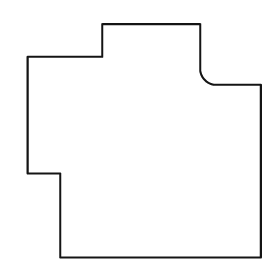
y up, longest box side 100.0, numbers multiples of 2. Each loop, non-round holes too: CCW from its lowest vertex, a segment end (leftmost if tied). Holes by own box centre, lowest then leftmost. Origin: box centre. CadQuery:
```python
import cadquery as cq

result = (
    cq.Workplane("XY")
    .moveTo(-36.0, -50.0)
    .lineTo(50.0, -50.0)
    .lineTo(50.0, 24.0)
    .lineTo(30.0, 24.0)
    .threePointArc((26.0, 26.0), (24.0, 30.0))
    .lineTo(24.0, 50.0)
    .lineTo(-18.0, 50.0)
    .lineTo(-18.0, 36.0)
    .lineTo(-50.0, 36.0)
    .lineTo(-50.0, -14.0)
    .lineTo(-36.0, -14.0)
    .close()
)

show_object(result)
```